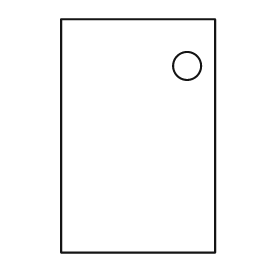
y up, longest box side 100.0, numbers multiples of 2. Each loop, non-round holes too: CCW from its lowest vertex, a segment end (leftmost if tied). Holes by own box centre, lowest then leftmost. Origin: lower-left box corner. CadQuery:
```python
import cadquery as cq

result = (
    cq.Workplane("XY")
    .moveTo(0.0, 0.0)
    .lineTo(66.0, 0.0)
    .lineTo(66.0, 100.0)
    .lineTo(0.0, 100.0)
    .close()
    .moveTo(54.0, 80.0)
    .circle(6.0)
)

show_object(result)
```